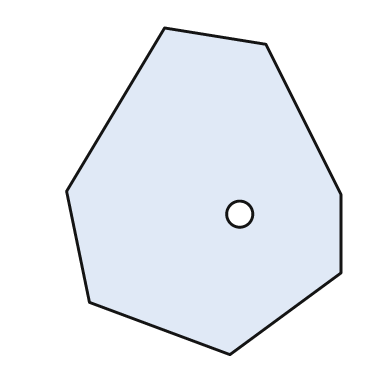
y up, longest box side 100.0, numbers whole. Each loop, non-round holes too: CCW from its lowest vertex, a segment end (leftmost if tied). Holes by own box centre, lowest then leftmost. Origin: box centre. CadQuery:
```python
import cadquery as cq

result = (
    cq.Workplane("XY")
    .moveTo(8.0, -50.0)
    .lineTo(42.0, -25.0)
    .lineTo(42.0, -1.0)
    .lineTo(19.0, 45.0)
    .lineTo(-12.0, 50.0)
    .lineTo(-42.0, 0.0)
    .lineTo(-35.0, -34.0)
    .close()
    .moveTo(11.0, -7.0)
    .circle(4.0)
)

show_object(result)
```